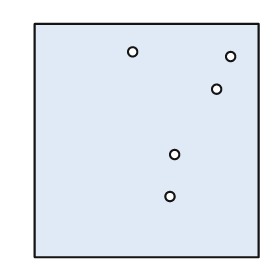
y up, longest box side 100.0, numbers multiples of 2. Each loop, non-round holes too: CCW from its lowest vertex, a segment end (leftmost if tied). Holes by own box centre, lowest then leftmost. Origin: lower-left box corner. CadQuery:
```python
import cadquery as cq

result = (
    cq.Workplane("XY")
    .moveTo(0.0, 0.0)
    .lineTo(96.0, 0.0)
    .lineTo(96.0, 100.0)
    .lineTo(0.0, 100.0)
    .close()
    .moveTo(58.0, 26.0)
    .circle(2.0)
    .moveTo(60.0, 44.0)
    .circle(2.0)
    .moveTo(78.0, 72.0)
    .circle(2.0)
    .moveTo(84.0, 86.0)
    .circle(2.0)
    .moveTo(42.0, 88.0)
    .circle(2.0)
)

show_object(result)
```